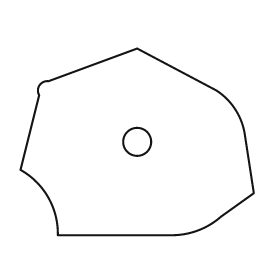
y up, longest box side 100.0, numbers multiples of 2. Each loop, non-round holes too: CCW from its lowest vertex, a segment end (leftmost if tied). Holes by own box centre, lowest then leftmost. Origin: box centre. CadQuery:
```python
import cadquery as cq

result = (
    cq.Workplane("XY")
    .moveTo(-34.0, -40.0)
    .lineTo(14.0, -40.0)
    .threePointArc((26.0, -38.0), (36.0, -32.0))
    .lineTo(50.0, -22.0)
    .lineTo(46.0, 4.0)
    .threePointArc((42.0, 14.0), (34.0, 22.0))
    .lineTo(0.0, 40.0)
    .lineTo(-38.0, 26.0)
    .threePointArc((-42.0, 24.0), (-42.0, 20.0))
    .lineTo(-50.0, -12.0)
    .threePointArc((-38.0, -24.0), (-34.0, -40.0))
    .close()
    .moveTo(0.0, 0.0)
    .circle(6.0)
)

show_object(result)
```